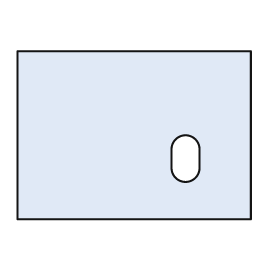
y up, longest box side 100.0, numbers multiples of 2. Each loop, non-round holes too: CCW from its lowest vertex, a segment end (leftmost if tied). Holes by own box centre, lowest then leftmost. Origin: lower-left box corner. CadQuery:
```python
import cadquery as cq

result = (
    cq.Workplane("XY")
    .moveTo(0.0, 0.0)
    .lineTo(100.0, 0.0)
    .lineTo(100.0, 72.0)
    .lineTo(0.0, 72.0)
    .close()
    .moveTo(66.0, 22.0)
    .threePointArc((72.0, 16.0), (78.0, 22.0))
    .lineTo(78.0, 30.0)
    .threePointArc((72.0, 36.0), (66.0, 30.0))
    .close()
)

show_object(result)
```